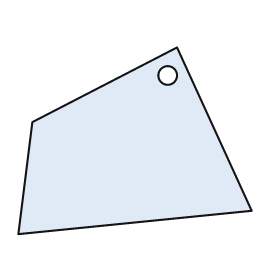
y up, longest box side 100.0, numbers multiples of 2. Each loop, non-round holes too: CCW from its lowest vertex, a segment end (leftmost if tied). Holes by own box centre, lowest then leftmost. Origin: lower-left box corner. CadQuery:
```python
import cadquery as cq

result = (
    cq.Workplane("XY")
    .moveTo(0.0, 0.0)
    .lineTo(100.0, 10.0)
    .lineTo(68.0, 80.0)
    .lineTo(6.0, 48.0)
    .close()
    .moveTo(64.0, 68.0)
    .circle(4.0)
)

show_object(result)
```